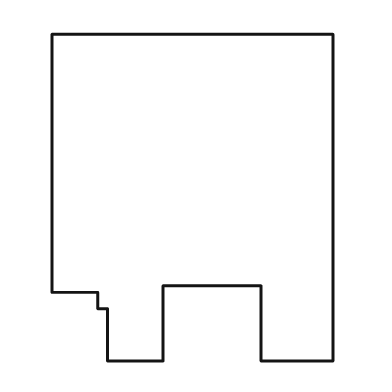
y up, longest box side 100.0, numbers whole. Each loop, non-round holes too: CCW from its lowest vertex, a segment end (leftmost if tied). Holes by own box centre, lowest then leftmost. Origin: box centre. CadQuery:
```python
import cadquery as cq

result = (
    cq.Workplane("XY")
    .moveTo(-26.0, -50.0)
    .lineTo(-9.0, -50.0)
    .lineTo(-9.0, -27.0)
    .lineTo(21.0, -27.0)
    .lineTo(21.0, -50.0)
    .lineTo(43.0, -50.0)
    .lineTo(43.0, 50.0)
    .lineTo(-43.0, 50.0)
    .lineTo(-43.0, -29.0)
    .lineTo(-29.0, -29.0)
    .lineTo(-29.0, -34.0)
    .lineTo(-26.0, -34.0)
    .close()
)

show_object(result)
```